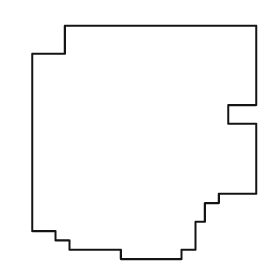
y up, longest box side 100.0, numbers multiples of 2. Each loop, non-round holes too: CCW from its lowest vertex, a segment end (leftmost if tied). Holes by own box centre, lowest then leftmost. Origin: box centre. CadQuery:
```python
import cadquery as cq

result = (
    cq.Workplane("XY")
    .moveTo(-10.0, -50.0)
    .lineTo(16.0, -50.0)
    .lineTo(16.0, -46.0)
    .lineTo(22.0, -46.0)
    .lineTo(22.0, -34.0)
    .lineTo(26.0, -34.0)
    .lineTo(26.0, -26.0)
    .lineTo(32.0, -26.0)
    .lineTo(32.0, -22.0)
    .lineTo(48.0, -22.0)
    .lineTo(48.0, 8.0)
    .lineTo(36.0, 8.0)
    .lineTo(36.0, 16.0)
    .lineTo(48.0, 16.0)
    .lineTo(48.0, 50.0)
    .lineTo(-34.0, 50.0)
    .lineTo(-34.0, 38.0)
    .lineTo(-48.0, 38.0)
    .lineTo(-48.0, -38.0)
    .lineTo(-38.0, -38.0)
    .lineTo(-38.0, -42.0)
    .lineTo(-32.0, -42.0)
    .lineTo(-32.0, -46.0)
    .lineTo(-10.0, -46.0)
    .close()
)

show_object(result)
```